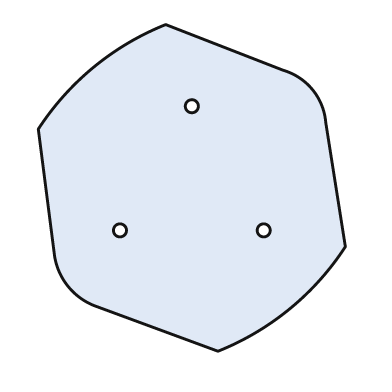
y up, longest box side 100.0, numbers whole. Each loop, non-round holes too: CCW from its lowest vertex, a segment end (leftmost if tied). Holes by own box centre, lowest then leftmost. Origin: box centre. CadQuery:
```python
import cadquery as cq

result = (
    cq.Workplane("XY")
    .moveTo(8.0, -50.0)
    .threePointArc((30.0, -37.0), (47.0, -18.0))
    .lineTo(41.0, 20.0)
    .threePointArc((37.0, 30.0), (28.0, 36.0))
    .lineTo(-8.0, 50.0)
    .threePointArc((-30.0, 37.0), (-47.0, 18.0))
    .lineTo(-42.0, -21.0)
    .threePointArc((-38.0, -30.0), (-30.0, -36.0))
    .close()
    .moveTo(-22.0, -13.0)
    .circle(2.0)
    .moveTo(22.0, -13.0)
    .circle(2.0)
    .moveTo(0.0, 25.0)
    .circle(2.0)
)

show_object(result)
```